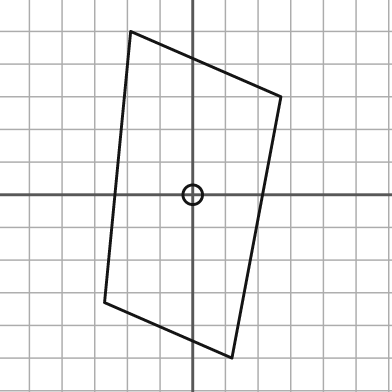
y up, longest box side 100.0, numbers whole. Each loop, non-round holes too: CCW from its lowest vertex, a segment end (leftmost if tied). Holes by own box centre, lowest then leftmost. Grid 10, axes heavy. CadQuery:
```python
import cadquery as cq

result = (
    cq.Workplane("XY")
    .moveTo(12.0, -50.0)
    .lineTo(27.0, 30.0)
    .lineTo(-19.0, 50.0)
    .lineTo(-27.0, -33.0)
    .close()
    .moveTo(0.0, 0.0)
    .circle(3.0)
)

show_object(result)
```